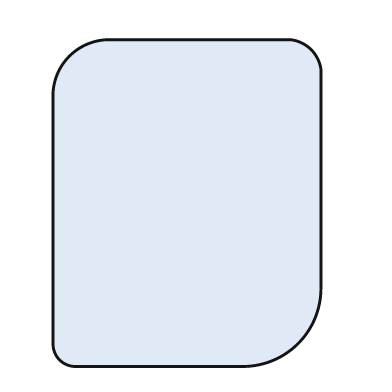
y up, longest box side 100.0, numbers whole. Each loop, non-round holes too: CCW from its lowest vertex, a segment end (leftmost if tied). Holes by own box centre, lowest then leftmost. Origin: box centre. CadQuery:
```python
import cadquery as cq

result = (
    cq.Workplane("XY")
    .moveTo(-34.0, -50.0)
    .lineTo(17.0, -50.0)
    .threePointArc((34.0, -43.0), (41.0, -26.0))
    .lineTo(41.0, 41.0)
    .threePointArc((38.0, 47.0), (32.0, 50.0))
    .lineTo(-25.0, 50.0)
    .threePointArc((-36.0, 45.0), (-41.0, 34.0))
    .lineTo(-41.0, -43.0)
    .threePointArc((-39.0, -48.0), (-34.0, -50.0))
    .close()
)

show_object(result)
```